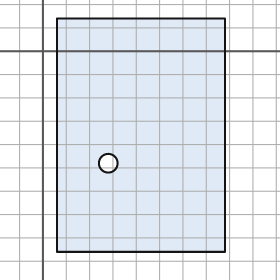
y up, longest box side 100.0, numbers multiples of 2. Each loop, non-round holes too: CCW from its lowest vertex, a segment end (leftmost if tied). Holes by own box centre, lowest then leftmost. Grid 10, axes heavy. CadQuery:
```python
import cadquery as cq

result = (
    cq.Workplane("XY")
    .moveTo(6.0, -86.0)
    .lineTo(78.0, -86.0)
    .lineTo(78.0, 14.0)
    .lineTo(6.0, 14.0)
    .close()
    .moveTo(28.0, -48.0)
    .circle(4.0)
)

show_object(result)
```